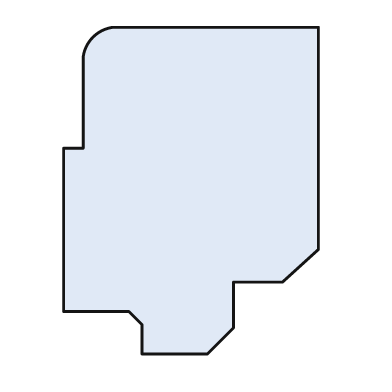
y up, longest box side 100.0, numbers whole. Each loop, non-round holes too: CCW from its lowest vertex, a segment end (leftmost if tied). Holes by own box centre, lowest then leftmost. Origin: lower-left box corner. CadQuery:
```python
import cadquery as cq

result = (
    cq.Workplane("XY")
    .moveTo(24.0, 0.0)
    .lineTo(44.0, 0.0)
    .lineTo(52.0, 8.0)
    .lineTo(52.0, 22.0)
    .lineTo(67.0, 22.0)
    .lineTo(78.0, 32.0)
    .lineTo(78.0, 100.0)
    .lineTo(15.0, 100.0)
    .threePointArc((9.0, 97.0), (6.0, 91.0))
    .lineTo(6.0, 63.0)
    .lineTo(0.0, 63.0)
    .lineTo(0.0, 13.0)
    .lineTo(20.0, 13.0)
    .lineTo(24.0, 9.0)
    .close()
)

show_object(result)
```